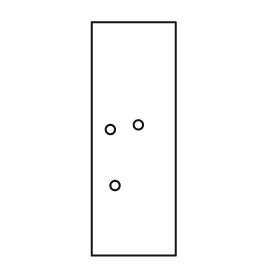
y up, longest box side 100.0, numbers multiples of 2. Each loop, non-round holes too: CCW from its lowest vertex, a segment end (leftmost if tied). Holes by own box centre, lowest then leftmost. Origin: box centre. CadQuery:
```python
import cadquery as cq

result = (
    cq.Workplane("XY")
    .moveTo(-18.0, -50.0)
    .lineTo(18.0, -50.0)
    .lineTo(18.0, 50.0)
    .lineTo(-18.0, 50.0)
    .close()
    .moveTo(-8.0, -20.0)
    .circle(2.0)
    .moveTo(-10.0, 4.0)
    .circle(2.0)
    .moveTo(2.0, 6.0)
    .circle(2.0)
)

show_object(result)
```